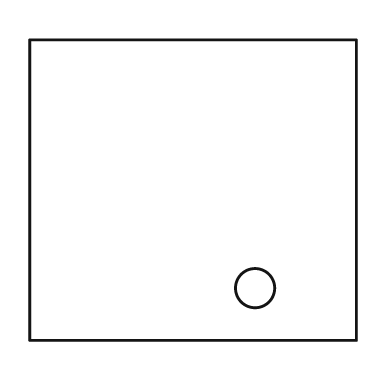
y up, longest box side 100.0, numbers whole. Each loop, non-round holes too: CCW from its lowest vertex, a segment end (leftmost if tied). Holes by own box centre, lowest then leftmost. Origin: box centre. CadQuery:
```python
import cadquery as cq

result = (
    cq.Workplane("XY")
    .moveTo(-50.0, -46.0)
    .lineTo(50.0, -46.0)
    .lineTo(50.0, 46.0)
    .lineTo(-50.0, 46.0)
    .close()
    .moveTo(19.0, -30.0)
    .circle(6.0)
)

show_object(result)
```